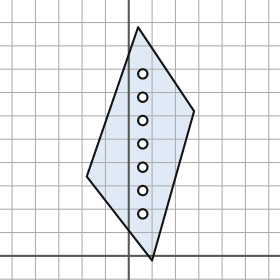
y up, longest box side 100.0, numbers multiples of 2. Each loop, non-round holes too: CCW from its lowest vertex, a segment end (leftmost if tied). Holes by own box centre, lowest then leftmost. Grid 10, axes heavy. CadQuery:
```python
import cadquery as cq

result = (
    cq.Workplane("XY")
    .moveTo(10.0, -2.0)
    .lineTo(28.0, 62.0)
    .lineTo(4.0, 98.0)
    .lineTo(-18.0, 34.0)
    .close()
    .moveTo(6.0, 18.0)
    .circle(2.0)
    .moveTo(6.0, 28.0)
    .circle(2.0)
    .moveTo(6.0, 38.0)
    .circle(2.0)
    .moveTo(6.0, 48.0)
    .circle(2.0)
    .moveTo(6.0, 58.0)
    .circle(2.0)
    .moveTo(6.0, 68.0)
    .circle(2.0)
    .moveTo(6.0, 78.0)
    .circle(2.0)
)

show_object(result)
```